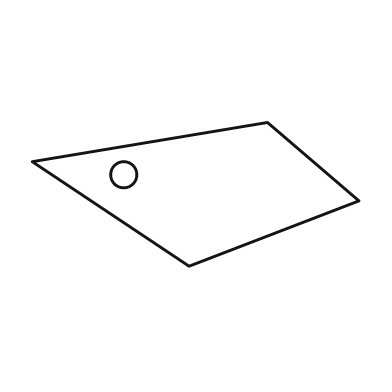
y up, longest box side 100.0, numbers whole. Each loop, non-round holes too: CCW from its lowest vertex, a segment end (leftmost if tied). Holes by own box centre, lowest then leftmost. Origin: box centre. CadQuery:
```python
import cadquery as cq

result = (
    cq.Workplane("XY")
    .moveTo(-2.0, -22.0)
    .lineTo(50.0, -2.0)
    .lineTo(22.0, 22.0)
    .lineTo(-50.0, 10.0)
    .close()
    .moveTo(-22.0, 6.0)
    .circle(4.0)
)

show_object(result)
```